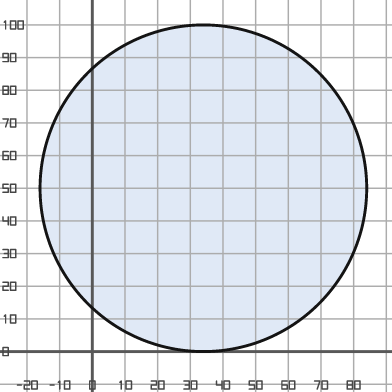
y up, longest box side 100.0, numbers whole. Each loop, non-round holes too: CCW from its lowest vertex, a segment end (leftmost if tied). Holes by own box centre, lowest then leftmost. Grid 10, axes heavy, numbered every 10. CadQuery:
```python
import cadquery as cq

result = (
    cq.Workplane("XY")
    .moveTo(34.0, 50.0)
    .circle(50.0)
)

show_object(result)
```